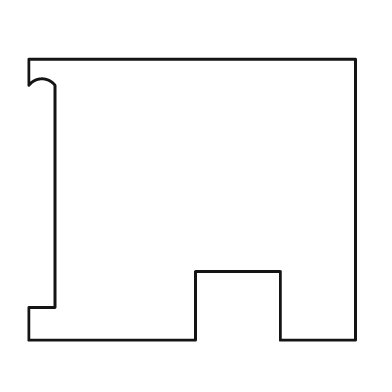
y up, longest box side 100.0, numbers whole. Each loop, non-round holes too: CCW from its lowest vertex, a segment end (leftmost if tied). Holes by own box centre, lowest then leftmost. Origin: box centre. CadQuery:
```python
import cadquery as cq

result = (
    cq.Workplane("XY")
    .moveTo(-50.0, -43.0)
    .lineTo(1.0, -43.0)
    .lineTo(1.0, -22.0)
    .lineTo(27.0, -22.0)
    .lineTo(27.0, -43.0)
    .lineTo(50.0, -43.0)
    .lineTo(50.0, 43.0)
    .lineTo(-50.0, 43.0)
    .lineTo(-50.0, 35.0)
    .threePointArc((-46.0, 37.0), (-42.0, 35.0))
    .lineTo(-42.0, -33.0)
    .lineTo(-50.0, -33.0)
    .close()
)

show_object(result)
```